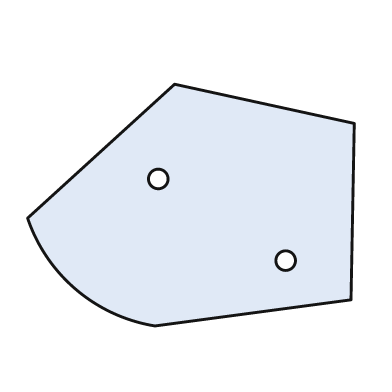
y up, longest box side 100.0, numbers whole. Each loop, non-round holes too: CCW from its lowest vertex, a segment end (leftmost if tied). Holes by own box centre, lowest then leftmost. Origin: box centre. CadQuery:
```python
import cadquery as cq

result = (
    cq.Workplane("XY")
    .moveTo(-11.0, -37.0)
    .lineTo(49.0, -29.0)
    .lineTo(50.0, 25.0)
    .lineTo(-5.0, 37.0)
    .lineTo(-50.0, -4.0)
    .threePointArc((-35.0, -26.0), (-11.0, -37.0))
    .close()
    .moveTo(29.0, -17.0)
    .circle(3.0)
    .moveTo(-10.0, 8.0)
    .circle(3.0)
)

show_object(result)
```